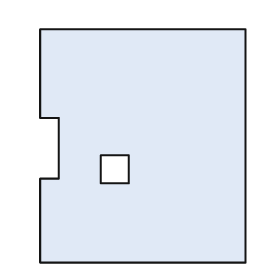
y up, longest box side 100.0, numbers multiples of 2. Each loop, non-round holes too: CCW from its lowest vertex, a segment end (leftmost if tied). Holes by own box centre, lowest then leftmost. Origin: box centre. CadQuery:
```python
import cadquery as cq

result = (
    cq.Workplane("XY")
    .moveTo(-44.0, -50.0)
    .lineTo(44.0, -50.0)
    .lineTo(44.0, 50.0)
    .lineTo(-44.0, 50.0)
    .lineTo(-44.0, 12.0)
    .lineTo(-36.0, 12.0)
    .lineTo(-36.0, -14.0)
    .lineTo(-44.0, -14.0)
    .close()
    .moveTo(-18.0, -16.0)
    .lineTo(-6.0, -16.0)
    .lineTo(-6.0, -4.0)
    .lineTo(-18.0, -4.0)
    .close()
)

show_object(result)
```